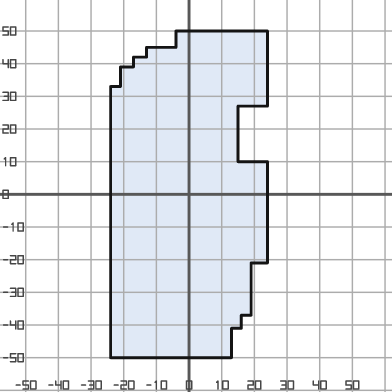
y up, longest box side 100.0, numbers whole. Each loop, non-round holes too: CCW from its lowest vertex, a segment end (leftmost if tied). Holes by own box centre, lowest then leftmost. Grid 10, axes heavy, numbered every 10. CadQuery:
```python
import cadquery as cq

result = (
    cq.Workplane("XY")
    .moveTo(-24.0, -50.0)
    .lineTo(13.0, -50.0)
    .lineTo(13.0, -41.0)
    .lineTo(16.0, -41.0)
    .lineTo(16.0, -37.0)
    .lineTo(19.0, -37.0)
    .lineTo(19.0, -21.0)
    .lineTo(24.0, -21.0)
    .lineTo(24.0, 10.0)
    .lineTo(15.0, 10.0)
    .lineTo(15.0, 27.0)
    .lineTo(24.0, 27.0)
    .lineTo(24.0, 50.0)
    .lineTo(-4.0, 50.0)
    .lineTo(-4.0, 45.0)
    .lineTo(-13.0, 45.0)
    .lineTo(-13.0, 42.0)
    .lineTo(-17.0, 42.0)
    .lineTo(-17.0, 39.0)
    .lineTo(-21.0, 39.0)
    .lineTo(-21.0, 33.0)
    .lineTo(-24.0, 33.0)
    .close()
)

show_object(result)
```